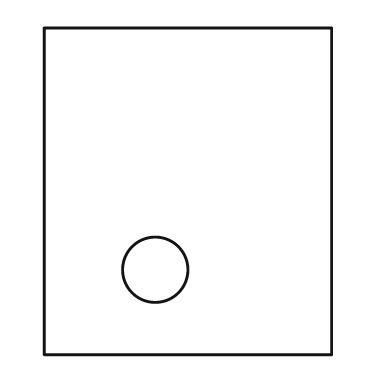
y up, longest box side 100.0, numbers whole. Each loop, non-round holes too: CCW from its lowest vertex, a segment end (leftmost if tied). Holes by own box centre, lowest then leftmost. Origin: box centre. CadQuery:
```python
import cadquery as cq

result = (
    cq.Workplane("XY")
    .moveTo(-44.0, -50.0)
    .lineTo(44.0, -50.0)
    .lineTo(44.0, 50.0)
    .lineTo(-44.0, 50.0)
    .close()
    .moveTo(-10.0, -24.0)
    .circle(10.0)
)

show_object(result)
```